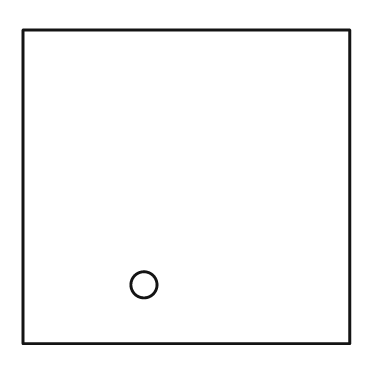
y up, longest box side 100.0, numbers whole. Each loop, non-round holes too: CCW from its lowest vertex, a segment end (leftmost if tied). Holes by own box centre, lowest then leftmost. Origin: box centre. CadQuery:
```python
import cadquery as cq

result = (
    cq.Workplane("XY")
    .moveTo(-50.0, -48.0)
    .lineTo(50.0, -48.0)
    .lineTo(50.0, 48.0)
    .lineTo(-50.0, 48.0)
    .close()
    .moveTo(-13.0, -30.0)
    .circle(4.0)
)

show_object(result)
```